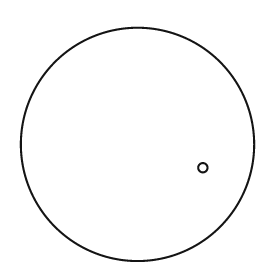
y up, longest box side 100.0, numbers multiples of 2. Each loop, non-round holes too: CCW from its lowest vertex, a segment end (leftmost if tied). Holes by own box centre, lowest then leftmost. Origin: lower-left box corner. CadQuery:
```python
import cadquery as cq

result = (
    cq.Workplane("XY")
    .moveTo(50.0, 50.0)
    .circle(50.0)
    .moveTo(78.0, 40.0)
    .circle(2.0)
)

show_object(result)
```